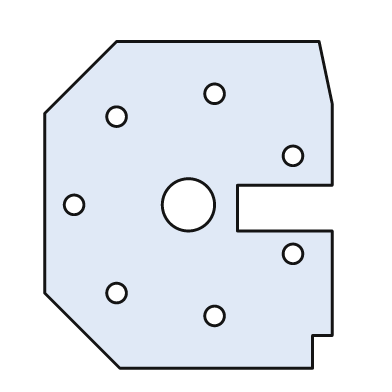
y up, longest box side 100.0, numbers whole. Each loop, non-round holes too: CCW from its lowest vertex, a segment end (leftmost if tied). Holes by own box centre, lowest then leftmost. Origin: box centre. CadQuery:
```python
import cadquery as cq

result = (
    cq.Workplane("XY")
    .moveTo(-21.0, -50.0)
    .lineTo(38.0, -50.0)
    .lineTo(38.0, -40.0)
    .lineTo(44.0, -40.0)
    .lineTo(44.0, -8.0)
    .lineTo(15.0, -8.0)
    .lineTo(15.0, 6.0)
    .lineTo(44.0, 6.0)
    .lineTo(44.0, 31.0)
    .lineTo(40.0, 50.0)
    .lineTo(-22.0, 50.0)
    .lineTo(-44.0, 28.0)
    .lineTo(-44.0, -27.0)
    .close()
    .moveTo(8.0, -34.0)
    .circle(3.0)
    .moveTo(-22.0, -27.0)
    .circle(3.0)
    .moveTo(32.0, -15.0)
    .circle(3.0)
    .moveTo(-35.0, 0.0)
    .circle(3.0)
    .moveTo(0.0, 0.0)
    .circle(8.0)
    .moveTo(32.0, 15.0)
    .circle(3.0)
    .moveTo(-22.0, 27.0)
    .circle(3.0)
    .moveTo(8.0, 34.0)
    .circle(3.0)
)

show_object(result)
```